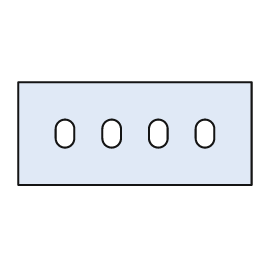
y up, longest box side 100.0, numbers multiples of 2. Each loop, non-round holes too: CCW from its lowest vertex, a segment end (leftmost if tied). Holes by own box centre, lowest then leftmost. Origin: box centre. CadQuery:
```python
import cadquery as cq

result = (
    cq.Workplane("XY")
    .moveTo(-50.0, -22.0)
    .lineTo(50.0, -22.0)
    .lineTo(50.0, 22.0)
    .lineTo(-50.0, 22.0)
    .close()
    .moveTo(-34.0, -2.0)
    .threePointArc((-30.0, -6.0), (-26.0, -2.0))
    .lineTo(-26.0, 2.0)
    .threePointArc((-30.0, 6.0), (-34.0, 2.0))
    .close()
    .moveTo(-14.0, -2.0)
    .threePointArc((-10.0, -6.0), (-6.0, -2.0))
    .lineTo(-6.0, 2.0)
    .threePointArc((-10.0, 6.0), (-14.0, 2.0))
    .close()
    .moveTo(6.0, -2.0)
    .threePointArc((10.0, -6.0), (14.0, -2.0))
    .lineTo(14.0, 2.0)
    .threePointArc((10.0, 6.0), (6.0, 2.0))
    .close()
    .moveTo(26.0, -2.0)
    .threePointArc((30.0, -6.0), (34.0, -2.0))
    .lineTo(34.0, 2.0)
    .threePointArc((30.0, 6.0), (26.0, 2.0))
    .close()
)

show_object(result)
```